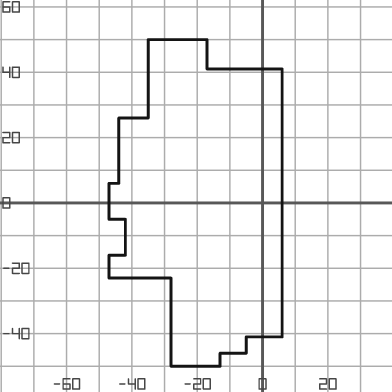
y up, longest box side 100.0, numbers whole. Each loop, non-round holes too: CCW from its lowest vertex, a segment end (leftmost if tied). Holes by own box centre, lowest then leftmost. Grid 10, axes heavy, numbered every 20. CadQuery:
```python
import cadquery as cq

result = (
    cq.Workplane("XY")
    .moveTo(-28.0, -50.0)
    .lineTo(-13.0, -50.0)
    .lineTo(-13.0, -46.0)
    .lineTo(-5.0, -46.0)
    .lineTo(-5.0, -41.0)
    .lineTo(6.0, -41.0)
    .lineTo(6.0, 41.0)
    .lineTo(-17.0, 41.0)
    .lineTo(-17.0, 50.0)
    .lineTo(-35.0, 50.0)
    .lineTo(-35.0, 26.0)
    .lineTo(-44.0, 26.0)
    .lineTo(-44.0, 6.0)
    .lineTo(-47.0, 6.0)
    .lineTo(-47.0, -5.0)
    .lineTo(-42.0, -5.0)
    .lineTo(-42.0, -16.0)
    .lineTo(-47.0, -16.0)
    .lineTo(-47.0, -23.0)
    .lineTo(-28.0, -23.0)
    .close()
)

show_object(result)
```